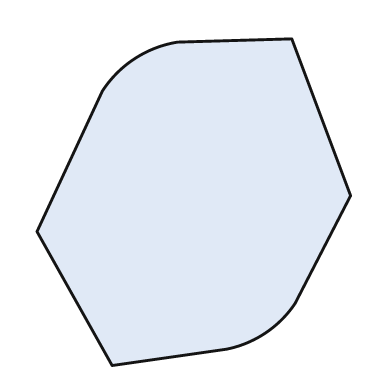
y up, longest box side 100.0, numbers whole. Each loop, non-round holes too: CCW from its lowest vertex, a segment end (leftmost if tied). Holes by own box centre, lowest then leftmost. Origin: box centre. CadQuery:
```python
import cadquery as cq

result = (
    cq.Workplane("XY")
    .moveTo(-25.0, -50.0)
    .lineTo(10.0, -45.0)
    .threePointArc((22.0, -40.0), (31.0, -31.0))
    .lineTo(48.0, 2.0)
    .lineTo(30.0, 50.0)
    .lineTo(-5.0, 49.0)
    .threePointArc((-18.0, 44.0), (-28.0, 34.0))
    .lineTo(-48.0, -9.0)
    .close()
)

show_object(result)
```